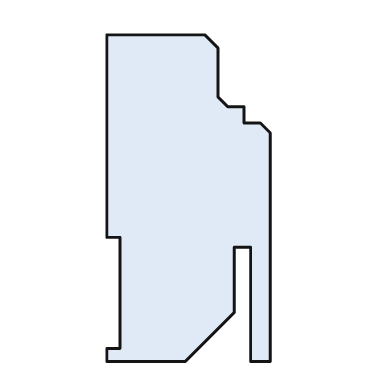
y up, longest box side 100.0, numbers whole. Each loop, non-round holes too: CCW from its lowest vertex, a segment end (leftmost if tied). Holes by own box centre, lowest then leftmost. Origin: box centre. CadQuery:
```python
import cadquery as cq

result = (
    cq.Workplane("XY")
    .moveTo(-25.0, -50.0)
    .lineTo(-1.0, -50.0)
    .lineTo(14.0, -35.0)
    .lineTo(14.0, -15.0)
    .lineTo(19.0, -15.0)
    .lineTo(19.0, -50.0)
    .lineTo(25.0, -50.0)
    .lineTo(25.0, 20.0)
    .lineTo(22.0, 23.0)
    .lineTo(17.0, 23.0)
    .lineTo(17.0, 28.0)
    .lineTo(12.0, 28.0)
    .lineTo(9.0, 31.0)
    .lineTo(9.0, 46.0)
    .lineTo(5.0, 50.0)
    .lineTo(-25.0, 50.0)
    .lineTo(-25.0, -12.0)
    .lineTo(-21.0, -12.0)
    .lineTo(-21.0, -46.0)
    .lineTo(-25.0, -46.0)
    .close()
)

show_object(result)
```